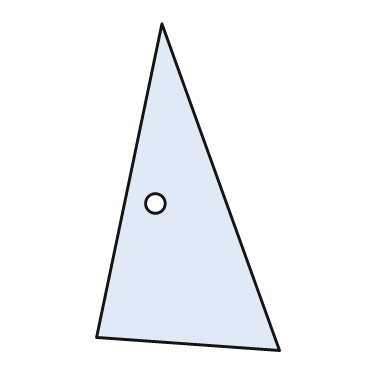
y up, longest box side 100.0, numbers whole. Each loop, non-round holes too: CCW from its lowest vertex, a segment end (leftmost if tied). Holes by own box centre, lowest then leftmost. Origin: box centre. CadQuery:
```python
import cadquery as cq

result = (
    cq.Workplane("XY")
    .moveTo(28.0, -50.0)
    .lineTo(-8.0, 50.0)
    .lineTo(-28.0, -46.0)
    .close()
    .moveTo(-10.0, -5.0)
    .circle(3.0)
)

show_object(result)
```